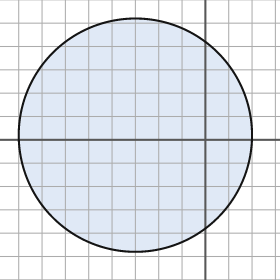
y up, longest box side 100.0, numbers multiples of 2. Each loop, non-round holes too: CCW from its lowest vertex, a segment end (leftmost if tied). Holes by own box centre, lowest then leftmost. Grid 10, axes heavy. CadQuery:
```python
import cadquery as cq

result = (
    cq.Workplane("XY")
    .moveTo(-30.0, 2.0)
    .circle(50.0)
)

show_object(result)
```